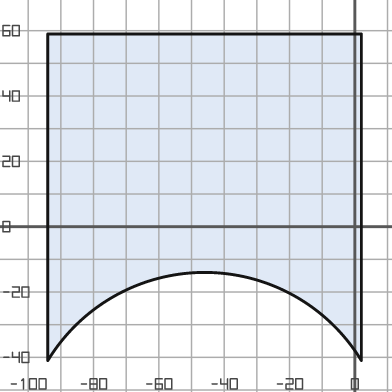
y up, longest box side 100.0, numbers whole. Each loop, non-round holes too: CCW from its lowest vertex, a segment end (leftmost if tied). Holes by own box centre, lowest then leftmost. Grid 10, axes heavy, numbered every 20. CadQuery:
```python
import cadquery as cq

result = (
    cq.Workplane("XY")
    .moveTo(-94.0, -41.0)
    .threePointArc((-46.0, -14.0), (2.0, -41.0))
    .lineTo(2.0, 59.0)
    .lineTo(-94.0, 59.0)
    .close()
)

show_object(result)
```